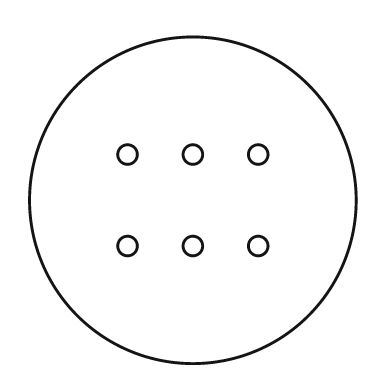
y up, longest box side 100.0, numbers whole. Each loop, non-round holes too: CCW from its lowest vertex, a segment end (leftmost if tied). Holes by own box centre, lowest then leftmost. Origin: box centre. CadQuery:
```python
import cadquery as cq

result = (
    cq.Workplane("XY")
    .moveTo(0.0, 0.0)
    .circle(50.0)
    .moveTo(-20.0, -14.0)
    .circle(3.0)
    .moveTo(0.0, -14.0)
    .circle(3.0)
    .moveTo(20.0, -14.0)
    .circle(3.0)
    .moveTo(-20.0, 14.0)
    .circle(3.0)
    .moveTo(0.0, 14.0)
    .circle(3.0)
    .moveTo(20.0, 14.0)
    .circle(3.0)
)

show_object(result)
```